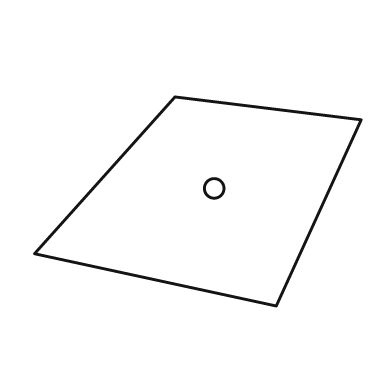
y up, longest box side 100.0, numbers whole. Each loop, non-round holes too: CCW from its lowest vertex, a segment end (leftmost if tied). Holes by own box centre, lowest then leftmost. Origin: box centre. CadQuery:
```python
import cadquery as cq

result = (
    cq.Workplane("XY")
    .moveTo(24.0, -32.0)
    .lineTo(50.0, 25.0)
    .lineTo(-7.0, 32.0)
    .lineTo(-50.0, -16.0)
    .close()
    .moveTo(5.0, 4.0)
    .circle(3.0)
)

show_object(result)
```